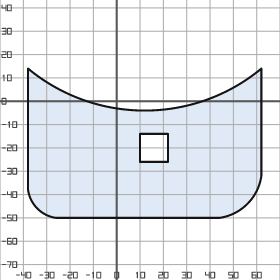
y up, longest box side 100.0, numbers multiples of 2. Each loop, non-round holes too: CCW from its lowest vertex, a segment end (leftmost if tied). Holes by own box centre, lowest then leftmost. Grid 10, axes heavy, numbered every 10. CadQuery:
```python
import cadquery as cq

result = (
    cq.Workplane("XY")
    .moveTo(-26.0, -50.0)
    .lineTo(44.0, -50.0)
    .threePointArc((56.0, -44.0), (62.0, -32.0))
    .lineTo(62.0, 14.0)
    .threePointArc((12.0, -4.0), (-38.0, 14.0))
    .lineTo(-38.0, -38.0)
    .threePointArc((-34.0, -46.0), (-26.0, -50.0))
    .close()
    .moveTo(10.0, -26.0)
    .lineTo(22.0, -26.0)
    .lineTo(22.0, -14.0)
    .lineTo(10.0, -14.0)
    .close()
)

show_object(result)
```